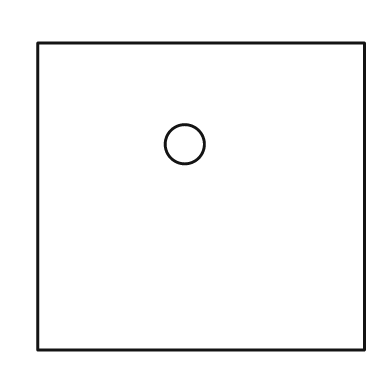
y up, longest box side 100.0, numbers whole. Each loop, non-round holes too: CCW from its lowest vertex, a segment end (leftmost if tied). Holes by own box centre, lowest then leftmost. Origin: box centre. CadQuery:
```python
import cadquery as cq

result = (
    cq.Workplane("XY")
    .moveTo(-50.0, -47.0)
    .lineTo(50.0, -47.0)
    .lineTo(50.0, 47.0)
    .lineTo(-50.0, 47.0)
    .close()
    .moveTo(-5.0, 16.0)
    .circle(6.0)
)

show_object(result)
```